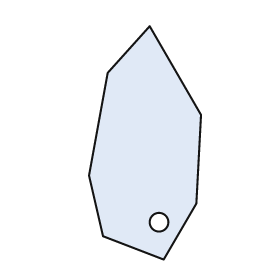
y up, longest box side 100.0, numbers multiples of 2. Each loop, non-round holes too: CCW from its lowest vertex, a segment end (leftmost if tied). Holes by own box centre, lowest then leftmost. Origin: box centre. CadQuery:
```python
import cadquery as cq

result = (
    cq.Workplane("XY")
    .moveTo(8.0, -50.0)
    .lineTo(22.0, -26.0)
    .lineTo(24.0, 12.0)
    .lineTo(2.0, 50.0)
    .lineTo(-16.0, 30.0)
    .lineTo(-24.0, -14.0)
    .lineTo(-18.0, -40.0)
    .close()
    .moveTo(6.0, -34.0)
    .circle(4.0)
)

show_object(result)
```